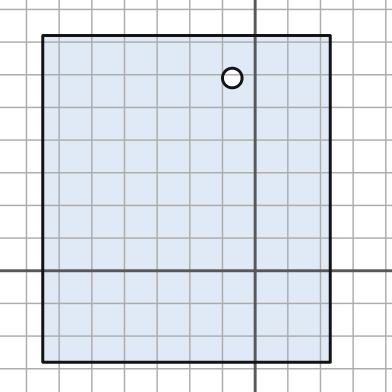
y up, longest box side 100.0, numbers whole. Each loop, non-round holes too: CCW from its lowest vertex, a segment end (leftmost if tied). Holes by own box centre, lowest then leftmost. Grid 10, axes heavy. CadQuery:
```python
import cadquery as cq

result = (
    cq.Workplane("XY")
    .moveTo(-65.0, -28.0)
    .lineTo(23.0, -28.0)
    .lineTo(23.0, 72.0)
    .lineTo(-65.0, 72.0)
    .close()
    .moveTo(-7.0, 59.0)
    .circle(3.0)
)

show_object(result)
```